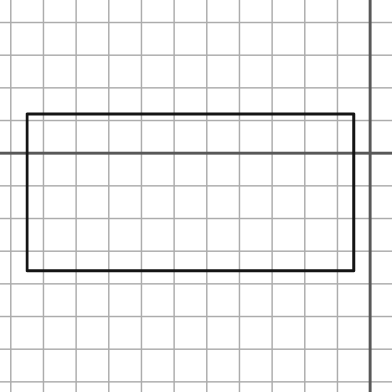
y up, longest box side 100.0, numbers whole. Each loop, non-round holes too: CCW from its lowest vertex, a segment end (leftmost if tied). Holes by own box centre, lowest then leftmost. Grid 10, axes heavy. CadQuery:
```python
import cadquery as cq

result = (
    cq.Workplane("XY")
    .moveTo(-105.0, -36.0)
    .lineTo(-5.0, -36.0)
    .lineTo(-5.0, 12.0)
    .lineTo(-105.0, 12.0)
    .close()
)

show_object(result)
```